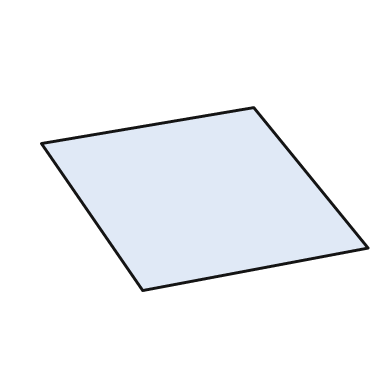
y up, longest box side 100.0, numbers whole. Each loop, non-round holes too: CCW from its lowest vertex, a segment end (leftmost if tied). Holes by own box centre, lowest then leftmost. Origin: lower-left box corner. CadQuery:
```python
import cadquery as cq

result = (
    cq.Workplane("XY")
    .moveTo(31.0, 0.0)
    .lineTo(100.0, 13.0)
    .lineTo(65.0, 56.0)
    .lineTo(0.0, 45.0)
    .close()
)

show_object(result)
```